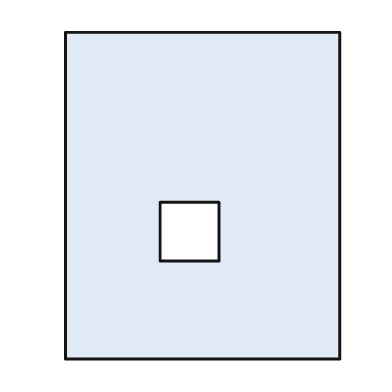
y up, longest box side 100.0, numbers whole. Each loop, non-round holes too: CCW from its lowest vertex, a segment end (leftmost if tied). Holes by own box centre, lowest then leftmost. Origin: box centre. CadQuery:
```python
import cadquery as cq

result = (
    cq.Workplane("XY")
    .moveTo(-42.0, -50.0)
    .lineTo(42.0, -50.0)
    .lineTo(42.0, 50.0)
    .lineTo(-42.0, 50.0)
    .close()
    .moveTo(-13.0, -20.0)
    .lineTo(5.0, -20.0)
    .lineTo(5.0, -2.0)
    .lineTo(-13.0, -2.0)
    .close()
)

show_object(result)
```